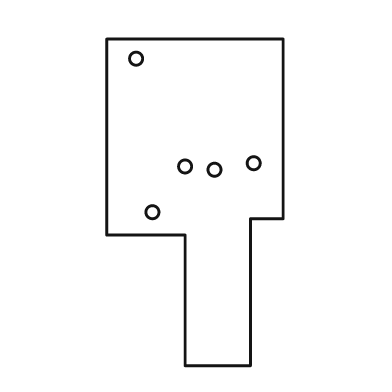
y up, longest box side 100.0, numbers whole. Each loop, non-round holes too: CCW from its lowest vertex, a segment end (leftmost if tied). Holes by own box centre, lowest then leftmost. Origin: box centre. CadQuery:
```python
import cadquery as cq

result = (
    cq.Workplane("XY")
    .moveTo(-3.0, -50.0)
    .lineTo(17.0, -50.0)
    .lineTo(17.0, -5.0)
    .lineTo(27.0, -5.0)
    .lineTo(27.0, 50.0)
    .lineTo(-27.0, 50.0)
    .lineTo(-27.0, -10.0)
    .lineTo(-3.0, -10.0)
    .close()
    .moveTo(-13.0, -3.0)
    .circle(2.0)
    .moveTo(6.0, 10.0)
    .circle(2.0)
    .moveTo(-3.0, 11.0)
    .circle(2.0)
    .moveTo(18.0, 12.0)
    .circle(2.0)
    .moveTo(-18.0, 44.0)
    .circle(2.0)
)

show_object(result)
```